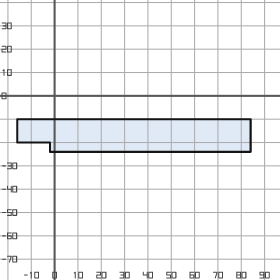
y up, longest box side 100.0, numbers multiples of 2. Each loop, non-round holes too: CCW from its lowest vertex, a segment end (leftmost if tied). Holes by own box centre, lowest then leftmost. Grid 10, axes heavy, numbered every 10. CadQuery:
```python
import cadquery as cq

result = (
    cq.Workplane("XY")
    .moveTo(-2.0, -24.0)
    .lineTo(84.0, -24.0)
    .lineTo(84.0, -10.0)
    .lineTo(-16.0, -10.0)
    .lineTo(-16.0, -20.0)
    .lineTo(-2.0, -20.0)
    .close()
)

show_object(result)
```